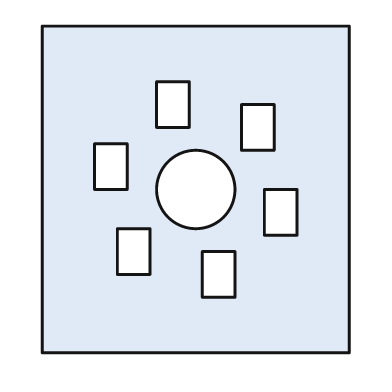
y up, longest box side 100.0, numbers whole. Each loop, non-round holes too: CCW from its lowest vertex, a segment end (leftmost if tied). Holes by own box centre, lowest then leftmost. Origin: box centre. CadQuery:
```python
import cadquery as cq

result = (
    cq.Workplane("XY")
    .moveTo(-47.0, -50.0)
    .lineTo(47.0, -50.0)
    .lineTo(47.0, 50.0)
    .lineTo(-47.0, 50.0)
    .close()
    .moveTo(2.0, -33.0)
    .lineTo(12.0, -33.0)
    .lineTo(12.0, -19.0)
    .lineTo(2.0, -19.0)
    .close()
    .moveTo(-24.0, -26.0)
    .lineTo(-14.0, -26.0)
    .lineTo(-14.0, -12.0)
    .lineTo(-24.0, -12.0)
    .close()
    .moveTo(21.0, -14.0)
    .lineTo(31.0, -14.0)
    .lineTo(31.0, 0.0)
    .lineTo(21.0, 0.0)
    .close()
    .moveTo(0.0, 0.0)
    .circle(12.0)
    .moveTo(-31.0, 0.0)
    .lineTo(-21.0, 0.0)
    .lineTo(-21.0, 14.0)
    .lineTo(-31.0, 14.0)
    .close()
    .moveTo(14.0, 12.0)
    .lineTo(24.0, 12.0)
    .lineTo(24.0, 26.0)
    .lineTo(14.0, 26.0)
    .close()
    .moveTo(-12.0, 19.0)
    .lineTo(-2.0, 19.0)
    .lineTo(-2.0, 33.0)
    .lineTo(-12.0, 33.0)
    .close()
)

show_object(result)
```